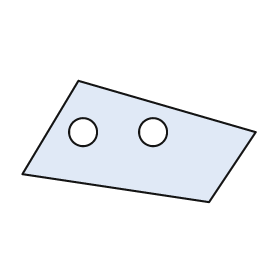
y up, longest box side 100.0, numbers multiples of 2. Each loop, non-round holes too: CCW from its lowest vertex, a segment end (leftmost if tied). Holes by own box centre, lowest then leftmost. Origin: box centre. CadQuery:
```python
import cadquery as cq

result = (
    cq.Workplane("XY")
    .moveTo(30.0, -26.0)
    .lineTo(50.0, 4.0)
    .lineTo(-26.0, 26.0)
    .lineTo(-50.0, -14.0)
    .close()
    .moveTo(-24.0, 4.0)
    .circle(6.0)
    .moveTo(6.0, 4.0)
    .circle(6.0)
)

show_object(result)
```